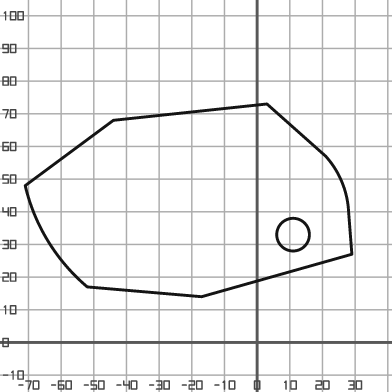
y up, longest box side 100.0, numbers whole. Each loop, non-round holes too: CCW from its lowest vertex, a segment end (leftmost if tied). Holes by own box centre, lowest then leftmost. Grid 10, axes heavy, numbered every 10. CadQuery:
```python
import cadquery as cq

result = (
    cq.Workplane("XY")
    .moveTo(-17.0, 14.0)
    .lineTo(29.0, 27.0)
    .lineTo(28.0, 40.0)
    .threePointArc((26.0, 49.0), (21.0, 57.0))
    .lineTo(3.0, 73.0)
    .lineTo(-44.0, 68.0)
    .lineTo(-71.0, 48.0)
    .threePointArc((-64.0, 31.0), (-52.0, 17.0))
    .close()
    .moveTo(11.0, 33.0)
    .circle(5.0)
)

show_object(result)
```